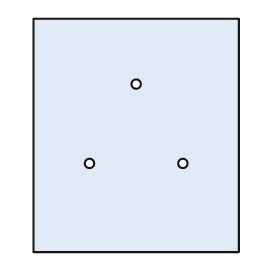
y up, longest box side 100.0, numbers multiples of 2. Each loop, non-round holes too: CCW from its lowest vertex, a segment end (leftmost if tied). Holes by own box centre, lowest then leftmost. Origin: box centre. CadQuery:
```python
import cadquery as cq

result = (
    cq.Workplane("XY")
    .moveTo(-44.0, -50.0)
    .lineTo(44.0, -50.0)
    .lineTo(44.0, 50.0)
    .lineTo(-44.0, 50.0)
    .close()
    .moveTo(-20.0, -12.0)
    .circle(2.0)
    .moveTo(20.0, -12.0)
    .circle(2.0)
    .moveTo(0.0, 22.0)
    .circle(2.0)
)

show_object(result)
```